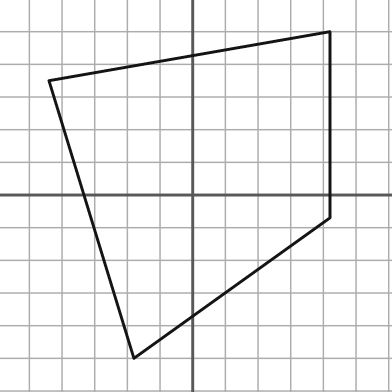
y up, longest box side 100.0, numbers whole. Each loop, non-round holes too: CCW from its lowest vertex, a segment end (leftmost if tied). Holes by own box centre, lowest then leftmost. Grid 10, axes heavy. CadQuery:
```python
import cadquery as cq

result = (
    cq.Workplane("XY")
    .moveTo(-18.0, -50.0)
    .lineTo(42.0, -7.0)
    .lineTo(42.0, 50.0)
    .lineTo(-44.0, 35.0)
    .close()
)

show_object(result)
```